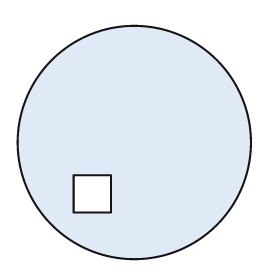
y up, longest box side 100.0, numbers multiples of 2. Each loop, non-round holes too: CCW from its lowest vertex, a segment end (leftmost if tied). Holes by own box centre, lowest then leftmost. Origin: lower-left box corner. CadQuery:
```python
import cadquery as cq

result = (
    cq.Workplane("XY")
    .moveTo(50.0, 50.0)
    .circle(50.0)
    .moveTo(24.0, 20.0)
    .lineTo(40.0, 20.0)
    .lineTo(40.0, 36.0)
    .lineTo(24.0, 36.0)
    .close()
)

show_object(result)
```